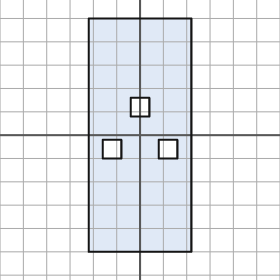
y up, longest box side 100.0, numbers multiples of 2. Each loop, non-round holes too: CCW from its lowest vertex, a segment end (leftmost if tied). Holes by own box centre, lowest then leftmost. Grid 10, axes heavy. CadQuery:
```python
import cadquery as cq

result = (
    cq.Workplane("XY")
    .moveTo(-22.0, -50.0)
    .lineTo(22.0, -50.0)
    .lineTo(22.0, 50.0)
    .lineTo(-22.0, 50.0)
    .close()
    .moveTo(-16.0, -10.0)
    .lineTo(-8.0, -10.0)
    .lineTo(-8.0, -2.0)
    .lineTo(-16.0, -2.0)
    .close()
    .moveTo(8.0, -10.0)
    .lineTo(16.0, -10.0)
    .lineTo(16.0, -2.0)
    .lineTo(8.0, -2.0)
    .close()
    .moveTo(-4.0, 8.0)
    .lineTo(4.0, 8.0)
    .lineTo(4.0, 16.0)
    .lineTo(-4.0, 16.0)
    .close()
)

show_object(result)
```